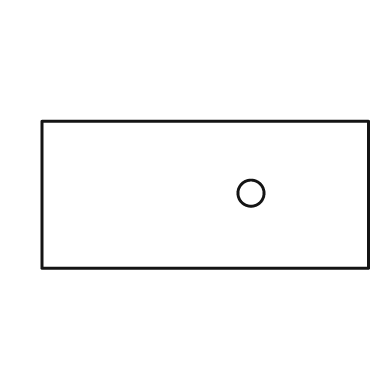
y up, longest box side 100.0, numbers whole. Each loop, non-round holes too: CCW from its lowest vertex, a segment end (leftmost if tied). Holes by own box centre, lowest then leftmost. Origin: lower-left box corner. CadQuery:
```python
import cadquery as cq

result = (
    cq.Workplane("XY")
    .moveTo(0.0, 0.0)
    .lineTo(100.0, 0.0)
    .lineTo(100.0, 45.0)
    .lineTo(0.0, 45.0)
    .close()
    .moveTo(64.0, 23.0)
    .circle(4.0)
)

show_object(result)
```